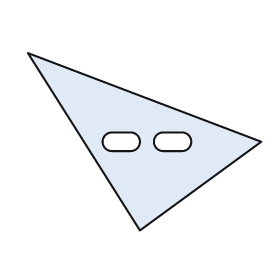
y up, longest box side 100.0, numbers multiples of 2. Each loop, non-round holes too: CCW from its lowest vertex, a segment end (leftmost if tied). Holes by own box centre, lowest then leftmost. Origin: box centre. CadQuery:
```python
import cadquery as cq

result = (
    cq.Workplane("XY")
    .moveTo(-2.0, -38.0)
    .lineTo(50.0, 0.0)
    .lineTo(-50.0, 38.0)
    .close()
    .moveTo(-14.0, -4.0)
    .lineTo(-6.0, -4.0)
    .threePointArc((-2.0, 0.0), (-6.0, 4.0))
    .lineTo(-14.0, 4.0)
    .threePointArc((-18.0, 0.0), (-14.0, -4.0))
    .close()
    .moveTo(8.0, -4.0)
    .lineTo(16.0, -4.0)
    .threePointArc((20.0, 0.0), (16.0, 4.0))
    .lineTo(8.0, 4.0)
    .threePointArc((4.0, 0.0), (8.0, -4.0))
    .close()
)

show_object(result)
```